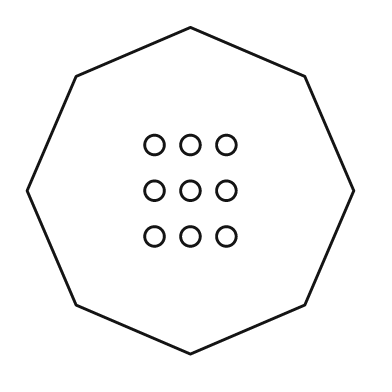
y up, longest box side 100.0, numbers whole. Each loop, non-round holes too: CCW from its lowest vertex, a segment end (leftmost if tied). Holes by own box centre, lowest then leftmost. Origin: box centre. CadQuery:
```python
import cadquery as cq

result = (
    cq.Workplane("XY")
    .moveTo(0.0, -50.0)
    .lineTo(35.0, -35.0)
    .lineTo(50.0, 0.0)
    .lineTo(35.0, 35.0)
    .lineTo(0.0, 50.0)
    .lineTo(-35.0, 35.0)
    .lineTo(-50.0, 0.0)
    .lineTo(-35.0, -35.0)
    .close()
    .moveTo(-11.0, -14.0)
    .circle(3.0)
    .moveTo(0.0, -14.0)
    .circle(3.0)
    .moveTo(11.0, -14.0)
    .circle(3.0)
    .moveTo(-11.0, 0.0)
    .circle(3.0)
    .moveTo(0.0, 0.0)
    .circle(3.0)
    .moveTo(11.0, 0.0)
    .circle(3.0)
    .moveTo(-11.0, 14.0)
    .circle(3.0)
    .moveTo(0.0, 14.0)
    .circle(3.0)
    .moveTo(11.0, 14.0)
    .circle(3.0)
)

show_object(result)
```